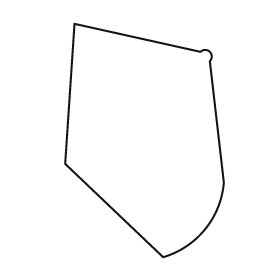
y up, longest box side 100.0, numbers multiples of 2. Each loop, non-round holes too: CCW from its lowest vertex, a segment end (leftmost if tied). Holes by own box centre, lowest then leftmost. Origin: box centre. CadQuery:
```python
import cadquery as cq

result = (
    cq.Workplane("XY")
    .moveTo(8.0, -50.0)
    .threePointArc((26.0, -38.0), (34.0, -18.0))
    .lineTo(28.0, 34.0)
    .threePointArc((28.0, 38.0), (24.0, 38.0))
    .lineTo(-30.0, 50.0)
    .lineTo(-34.0, -10.0)
    .close()
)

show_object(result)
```